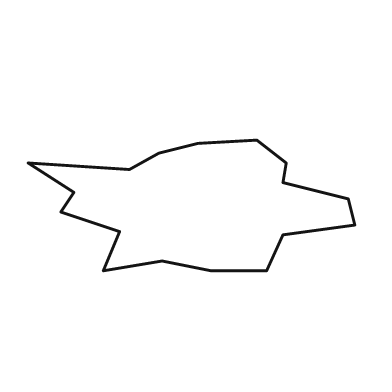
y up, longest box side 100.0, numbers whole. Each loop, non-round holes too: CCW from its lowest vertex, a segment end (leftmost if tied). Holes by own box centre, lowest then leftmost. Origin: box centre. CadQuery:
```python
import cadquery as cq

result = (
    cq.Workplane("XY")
    .moveTo(-27.0, -20.0)
    .lineTo(-9.0, -17.0)
    .lineTo(6.0, -20.0)
    .lineTo(23.0, -20.0)
    .lineTo(28.0, -9.0)
    .lineTo(50.0, -6.0)
    .lineTo(48.0, 2.0)
    .lineTo(28.0, 7.0)
    .lineTo(29.0, 13.0)
    .lineTo(20.0, 20.0)
    .lineTo(2.0, 19.0)
    .lineTo(-10.0, 16.0)
    .lineTo(-19.0, 11.0)
    .lineTo(-50.0, 13.0)
    .lineTo(-36.0, 4.0)
    .lineTo(-40.0, -2.0)
    .lineTo(-22.0, -8.0)
    .close()
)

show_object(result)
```